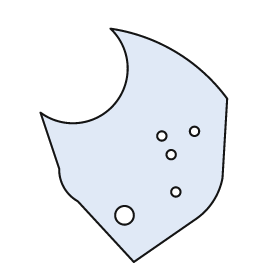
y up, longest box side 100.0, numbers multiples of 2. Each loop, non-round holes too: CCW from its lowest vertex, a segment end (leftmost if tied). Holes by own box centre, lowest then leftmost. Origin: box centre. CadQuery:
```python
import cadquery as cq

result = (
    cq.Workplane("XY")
    .moveTo(0.0, -50.0)
    .lineTo(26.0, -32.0)
    .threePointArc((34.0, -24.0), (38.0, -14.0))
    .lineTo(40.0, 20.0)
    .threePointArc((18.0, 40.0), (-10.0, 50.0))
    .threePointArc((-8.0, 18.0), (-40.0, 14.0))
    .lineTo(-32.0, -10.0)
    .threePointArc((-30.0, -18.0), (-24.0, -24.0))
    .close()
    .moveTo(-4.0, -30.0)
    .circle(4.0)
    .moveTo(18.0, -20.0)
    .circle(2.0)
    .moveTo(16.0, -4.0)
    .circle(2.0)
    .moveTo(12.0, 4.0)
    .circle(2.0)
    .moveTo(26.0, 6.0)
    .circle(2.0)
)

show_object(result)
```